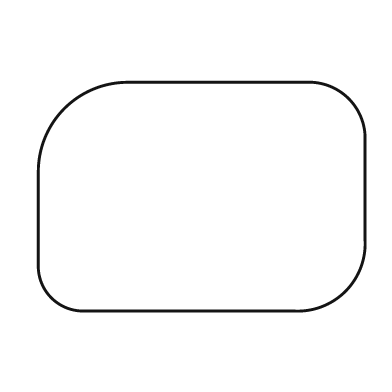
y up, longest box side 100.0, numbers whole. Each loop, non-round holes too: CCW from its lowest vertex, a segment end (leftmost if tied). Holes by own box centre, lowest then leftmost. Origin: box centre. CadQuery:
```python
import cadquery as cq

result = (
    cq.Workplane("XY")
    .moveTo(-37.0, -35.0)
    .lineTo(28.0, -35.0)
    .threePointArc((44.0, -29.0), (50.0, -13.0))
    .lineTo(50.0, 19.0)
    .threePointArc((45.0, 30.0), (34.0, 35.0))
    .lineTo(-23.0, 35.0)
    .threePointArc((-42.0, 27.0), (-50.0, 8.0))
    .lineTo(-50.0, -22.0)
    .threePointArc((-46.0, -31.0), (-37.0, -35.0))
    .close()
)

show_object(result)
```